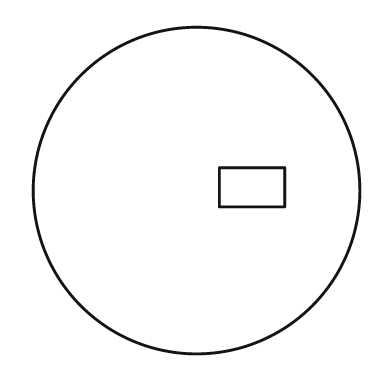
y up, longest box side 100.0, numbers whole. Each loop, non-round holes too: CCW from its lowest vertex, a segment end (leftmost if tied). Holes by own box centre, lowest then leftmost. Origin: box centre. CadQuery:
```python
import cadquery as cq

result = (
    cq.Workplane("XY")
    .moveTo(0.0, 0.0)
    .circle(50.0)
    .moveTo(7.0, -5.0)
    .lineTo(27.0, -5.0)
    .lineTo(27.0, 7.0)
    .lineTo(7.0, 7.0)
    .close()
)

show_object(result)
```